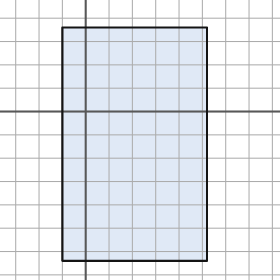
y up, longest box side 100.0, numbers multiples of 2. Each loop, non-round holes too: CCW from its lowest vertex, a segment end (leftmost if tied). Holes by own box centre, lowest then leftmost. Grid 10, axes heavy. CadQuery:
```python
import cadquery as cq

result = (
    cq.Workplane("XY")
    .moveTo(-10.0, -64.0)
    .lineTo(52.0, -64.0)
    .lineTo(52.0, 36.0)
    .lineTo(-10.0, 36.0)
    .close()
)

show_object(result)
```